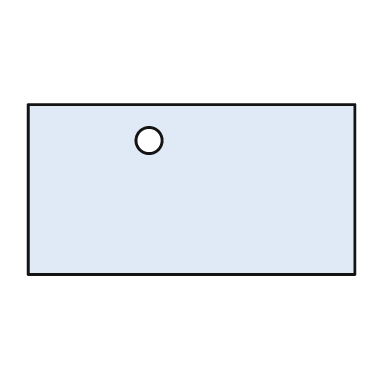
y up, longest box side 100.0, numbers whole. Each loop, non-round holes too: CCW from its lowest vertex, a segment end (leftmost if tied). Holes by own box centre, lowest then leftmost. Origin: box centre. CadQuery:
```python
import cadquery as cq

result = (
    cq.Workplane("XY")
    .moveTo(-50.0, -26.0)
    .lineTo(50.0, -26.0)
    .lineTo(50.0, 26.0)
    .lineTo(-50.0, 26.0)
    .close()
    .moveTo(-13.0, 15.0)
    .circle(4.0)
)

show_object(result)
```